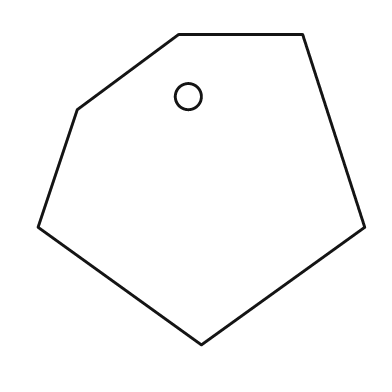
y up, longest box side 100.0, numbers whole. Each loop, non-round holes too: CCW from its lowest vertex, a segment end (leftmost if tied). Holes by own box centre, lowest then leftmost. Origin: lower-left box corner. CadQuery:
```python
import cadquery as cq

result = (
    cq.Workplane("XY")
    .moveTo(50.0, 0.0)
    .lineTo(100.0, 36.0)
    .lineTo(81.0, 95.0)
    .lineTo(43.0, 95.0)
    .lineTo(12.0, 72.0)
    .lineTo(0.0, 36.0)
    .close()
    .moveTo(46.0, 76.0)
    .circle(4.0)
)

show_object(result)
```